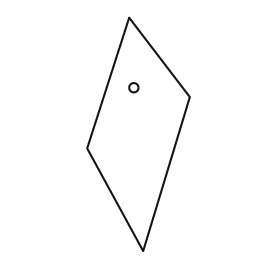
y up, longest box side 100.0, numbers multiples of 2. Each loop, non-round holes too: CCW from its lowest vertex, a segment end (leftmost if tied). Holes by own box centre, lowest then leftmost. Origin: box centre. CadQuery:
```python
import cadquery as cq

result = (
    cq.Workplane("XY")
    .moveTo(2.0, -50.0)
    .lineTo(22.0, 16.0)
    .lineTo(-4.0, 50.0)
    .lineTo(-22.0, -6.0)
    .close()
    .moveTo(-2.0, 20.0)
    .circle(2.0)
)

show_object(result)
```